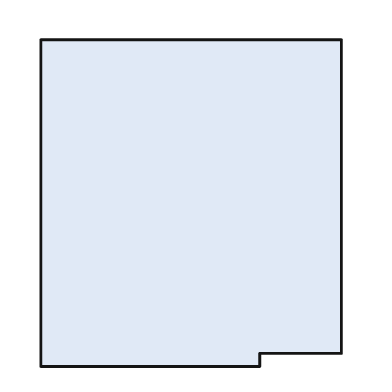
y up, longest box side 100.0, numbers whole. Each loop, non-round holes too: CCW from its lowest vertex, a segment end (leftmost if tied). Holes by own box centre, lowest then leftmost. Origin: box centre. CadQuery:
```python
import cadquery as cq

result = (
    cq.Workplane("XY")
    .moveTo(-46.0, -50.0)
    .lineTo(21.0, -50.0)
    .lineTo(21.0, -46.0)
    .lineTo(46.0, -46.0)
    .lineTo(46.0, 50.0)
    .lineTo(-46.0, 50.0)
    .close()
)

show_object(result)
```